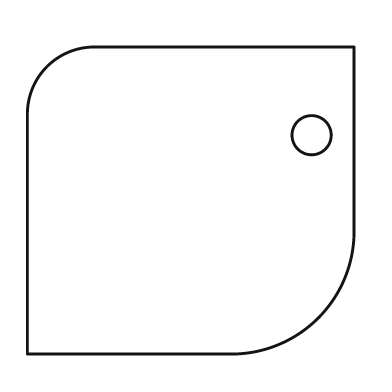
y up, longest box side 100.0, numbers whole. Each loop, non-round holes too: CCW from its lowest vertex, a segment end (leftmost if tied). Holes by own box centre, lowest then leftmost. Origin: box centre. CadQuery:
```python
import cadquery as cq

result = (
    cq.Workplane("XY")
    .moveTo(-50.0, -47.0)
    .lineTo(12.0, -47.0)
    .threePointArc((39.0, -36.0), (50.0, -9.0))
    .lineTo(50.0, 47.0)
    .lineTo(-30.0, 47.0)
    .threePointArc((-44.0, 41.0), (-50.0, 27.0))
    .close()
    .moveTo(37.0, 20.0)
    .circle(6.0)
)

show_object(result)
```